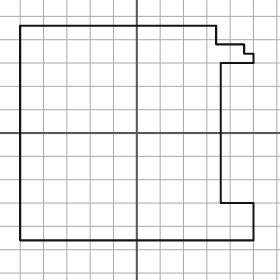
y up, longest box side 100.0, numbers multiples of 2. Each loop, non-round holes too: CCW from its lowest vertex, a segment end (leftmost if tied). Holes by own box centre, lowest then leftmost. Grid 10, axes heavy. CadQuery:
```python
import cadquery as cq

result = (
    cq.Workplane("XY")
    .moveTo(-50.0, -46.0)
    .lineTo(50.0, -46.0)
    .lineTo(50.0, -30.0)
    .lineTo(36.0, -30.0)
    .lineTo(36.0, 30.0)
    .lineTo(50.0, 30.0)
    .lineTo(50.0, 34.0)
    .lineTo(46.0, 34.0)
    .lineTo(46.0, 38.0)
    .lineTo(34.0, 38.0)
    .lineTo(34.0, 46.0)
    .lineTo(-50.0, 46.0)
    .close()
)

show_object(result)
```